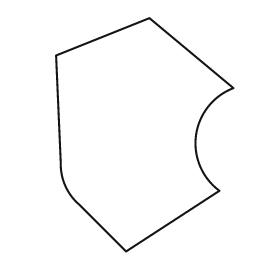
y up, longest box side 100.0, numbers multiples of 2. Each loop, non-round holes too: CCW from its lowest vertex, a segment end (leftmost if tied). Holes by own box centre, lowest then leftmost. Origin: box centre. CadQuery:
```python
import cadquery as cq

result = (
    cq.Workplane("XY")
    .moveTo(-8.0, -50.0)
    .lineTo(32.0, -24.0)
    .threePointArc((22.0, 0.0), (38.0, 20.0))
    .lineTo(2.0, 50.0)
    .lineTo(-38.0, 34.0)
    .lineTo(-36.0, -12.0)
    .threePointArc((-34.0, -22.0), (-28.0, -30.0))
    .close()
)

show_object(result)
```